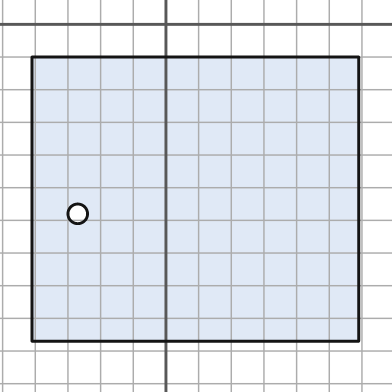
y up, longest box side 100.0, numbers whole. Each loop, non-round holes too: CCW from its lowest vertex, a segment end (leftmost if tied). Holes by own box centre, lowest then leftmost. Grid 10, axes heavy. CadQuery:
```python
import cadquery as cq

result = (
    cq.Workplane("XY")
    .moveTo(-41.0, -97.0)
    .lineTo(59.0, -97.0)
    .lineTo(59.0, -10.0)
    .lineTo(-41.0, -10.0)
    .close()
    .moveTo(-27.0, -58.0)
    .circle(3.0)
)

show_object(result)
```